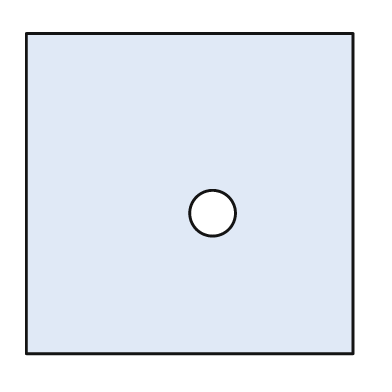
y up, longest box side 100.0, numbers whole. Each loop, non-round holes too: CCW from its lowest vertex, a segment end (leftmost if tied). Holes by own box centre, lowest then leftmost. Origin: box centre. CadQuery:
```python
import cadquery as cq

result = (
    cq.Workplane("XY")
    .moveTo(-50.0, -49.0)
    .lineTo(50.0, -49.0)
    .lineTo(50.0, 49.0)
    .lineTo(-50.0, 49.0)
    .close()
    .moveTo(7.0, -6.0)
    .circle(7.0)
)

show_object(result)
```